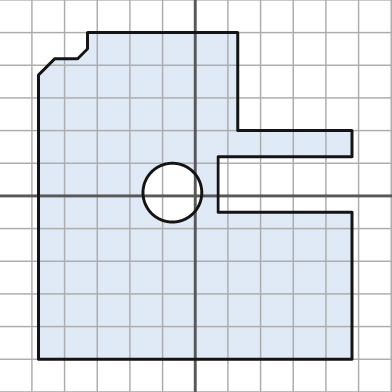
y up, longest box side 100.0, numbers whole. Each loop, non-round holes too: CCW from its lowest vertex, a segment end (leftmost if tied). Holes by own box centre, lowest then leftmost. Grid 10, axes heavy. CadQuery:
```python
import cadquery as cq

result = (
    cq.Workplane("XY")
    .moveTo(-48.0, -50.0)
    .lineTo(48.0, -50.0)
    .lineTo(48.0, -5.0)
    .lineTo(7.0, -5.0)
    .lineTo(7.0, 12.0)
    .lineTo(48.0, 12.0)
    .lineTo(48.0, 20.0)
    .lineTo(13.0, 20.0)
    .lineTo(13.0, 50.0)
    .lineTo(-33.0, 50.0)
    .lineTo(-33.0, 45.0)
    .lineTo(-36.0, 42.0)
    .lineTo(-43.0, 42.0)
    .lineTo(-48.0, 37.0)
    .close()
    .moveTo(-7.0, 1.0)
    .circle(9.0)
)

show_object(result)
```